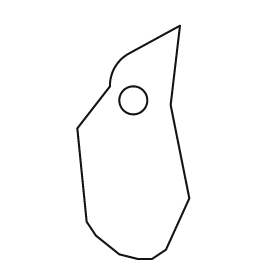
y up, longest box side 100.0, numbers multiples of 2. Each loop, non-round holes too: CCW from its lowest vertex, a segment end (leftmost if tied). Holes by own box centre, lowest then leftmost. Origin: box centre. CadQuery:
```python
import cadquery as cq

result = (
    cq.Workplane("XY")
    .moveTo(2.0, -50.0)
    .lineTo(8.0, -50.0)
    .lineTo(14.0, -46.0)
    .lineTo(24.0, -24.0)
    .lineTo(16.0, 16.0)
    .lineTo(20.0, 50.0)
    .lineTo(-2.0, 38.0)
    .threePointArc((-8.0, 32.0), (-10.0, 24.0))
    .lineTo(-24.0, 6.0)
    .lineTo(-20.0, -34.0)
    .lineTo(-16.0, -40.0)
    .lineTo(-6.0, -48.0)
    .close()
    .moveTo(0.0, 18.0)
    .circle(6.0)
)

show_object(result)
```